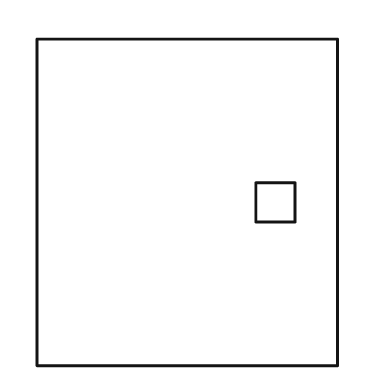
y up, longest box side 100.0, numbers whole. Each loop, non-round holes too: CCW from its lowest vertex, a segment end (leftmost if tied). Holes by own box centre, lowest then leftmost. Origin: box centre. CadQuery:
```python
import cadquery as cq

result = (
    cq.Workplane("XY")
    .moveTo(-46.0, -50.0)
    .lineTo(46.0, -50.0)
    .lineTo(46.0, 50.0)
    .lineTo(-46.0, 50.0)
    .close()
    .moveTo(21.0, -6.0)
    .lineTo(33.0, -6.0)
    .lineTo(33.0, 6.0)
    .lineTo(21.0, 6.0)
    .close()
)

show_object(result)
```